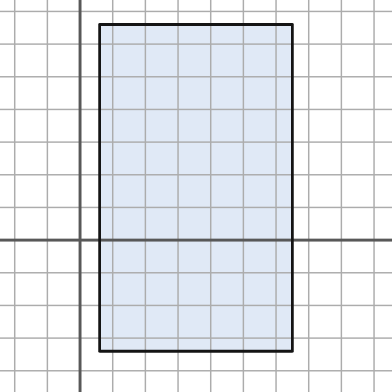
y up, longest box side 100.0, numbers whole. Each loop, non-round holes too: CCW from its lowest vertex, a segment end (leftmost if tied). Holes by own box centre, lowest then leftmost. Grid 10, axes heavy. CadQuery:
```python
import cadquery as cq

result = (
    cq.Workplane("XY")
    .moveTo(6.0, -34.0)
    .lineTo(65.0, -34.0)
    .lineTo(65.0, 66.0)
    .lineTo(6.0, 66.0)
    .close()
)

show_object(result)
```